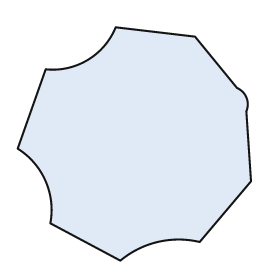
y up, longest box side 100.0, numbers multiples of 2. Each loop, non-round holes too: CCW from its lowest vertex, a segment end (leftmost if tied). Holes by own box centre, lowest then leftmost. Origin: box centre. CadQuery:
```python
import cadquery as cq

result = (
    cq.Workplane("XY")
    .moveTo(-6.0, -50.0)
    .threePointArc((10.0, -42.0), (28.0, -42.0))
    .lineTo(50.0, -16.0)
    .lineTo(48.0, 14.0)
    .threePointArc((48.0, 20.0), (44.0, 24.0))
    .lineTo(26.0, 46.0)
    .lineTo(-8.0, 50.0)
    .threePointArc((-20.0, 36.0), (-38.0, 32.0))
    .lineTo(-50.0, -2.0)
    .threePointArc((-38.0, -16.0), (-36.0, -34.0))
    .close()
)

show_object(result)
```